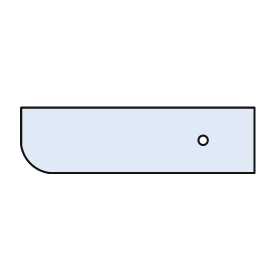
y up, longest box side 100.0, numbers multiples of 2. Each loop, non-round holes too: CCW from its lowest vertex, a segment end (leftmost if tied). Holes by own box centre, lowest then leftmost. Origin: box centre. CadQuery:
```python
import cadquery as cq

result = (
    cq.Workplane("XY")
    .moveTo(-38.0, -14.0)
    .lineTo(50.0, -14.0)
    .lineTo(50.0, 14.0)
    .lineTo(-50.0, 14.0)
    .lineTo(-50.0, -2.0)
    .threePointArc((-46.0, -10.0), (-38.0, -14.0))
    .close()
    .moveTo(28.0, 0.0)
    .circle(2.0)
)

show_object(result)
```